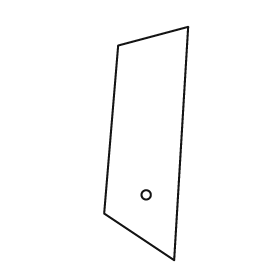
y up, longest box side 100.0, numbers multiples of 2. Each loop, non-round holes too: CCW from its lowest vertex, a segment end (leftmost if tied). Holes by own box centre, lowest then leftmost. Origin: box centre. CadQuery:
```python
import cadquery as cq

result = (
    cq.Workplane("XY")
    .moveTo(12.0, -50.0)
    .lineTo(18.0, 50.0)
    .lineTo(-12.0, 42.0)
    .lineTo(-18.0, -30.0)
    .close()
    .moveTo(0.0, -22.0)
    .circle(2.0)
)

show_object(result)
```